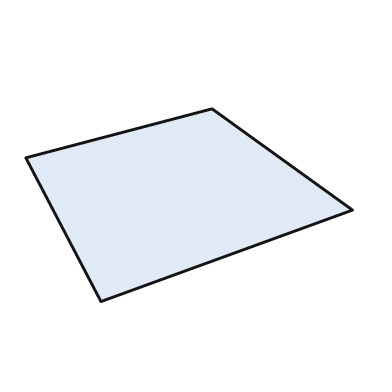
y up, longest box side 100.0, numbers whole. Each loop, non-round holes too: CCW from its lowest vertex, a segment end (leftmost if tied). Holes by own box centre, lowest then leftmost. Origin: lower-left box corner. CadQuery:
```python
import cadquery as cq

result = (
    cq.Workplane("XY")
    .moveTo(23.0, 0.0)
    .lineTo(100.0, 28.0)
    .lineTo(57.0, 59.0)
    .lineTo(0.0, 44.0)
    .close()
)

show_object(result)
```